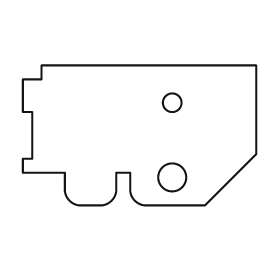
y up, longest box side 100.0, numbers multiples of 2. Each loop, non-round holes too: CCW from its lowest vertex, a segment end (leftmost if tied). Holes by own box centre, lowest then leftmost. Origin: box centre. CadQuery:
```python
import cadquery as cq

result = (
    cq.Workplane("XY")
    .moveTo(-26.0, -30.0)
    .lineTo(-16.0, -30.0)
    .threePointArc((-12.0, -28.0), (-10.0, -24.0))
    .lineTo(-10.0, -16.0)
    .lineTo(-4.0, -16.0)
    .lineTo(-4.0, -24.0)
    .threePointArc((-2.0, -28.0), (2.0, -30.0))
    .lineTo(28.0, -30.0)
    .lineTo(50.0, -8.0)
    .lineTo(50.0, 30.0)
    .lineTo(-42.0, 30.0)
    .lineTo(-42.0, 24.0)
    .lineTo(-50.0, 24.0)
    .lineTo(-50.0, 10.0)
    .lineTo(-46.0, 10.0)
    .lineTo(-46.0, -10.0)
    .lineTo(-50.0, -10.0)
    .lineTo(-50.0, -16.0)
    .lineTo(-32.0, -16.0)
    .lineTo(-32.0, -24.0)
    .threePointArc((-30.0, -28.0), (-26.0, -30.0))
    .close()
    .moveTo(14.0, -18.0)
    .circle(6.0)
    .moveTo(14.0, 14.0)
    .circle(4.0)
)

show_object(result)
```